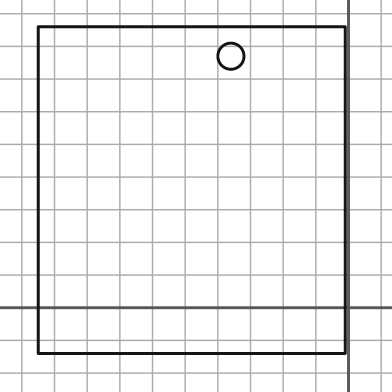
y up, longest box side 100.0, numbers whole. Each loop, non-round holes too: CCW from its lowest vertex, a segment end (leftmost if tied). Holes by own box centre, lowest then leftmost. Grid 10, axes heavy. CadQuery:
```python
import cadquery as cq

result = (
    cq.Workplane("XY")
    .moveTo(-95.0, -14.0)
    .lineTo(-1.0, -14.0)
    .lineTo(-1.0, 86.0)
    .lineTo(-95.0, 86.0)
    .close()
    .moveTo(-36.0, 77.0)
    .circle(4.0)
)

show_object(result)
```